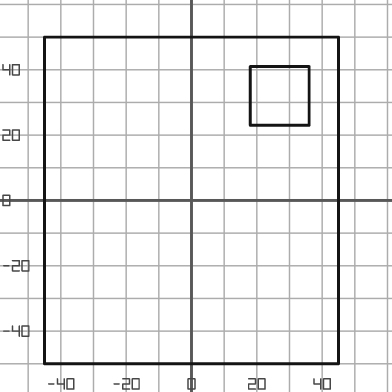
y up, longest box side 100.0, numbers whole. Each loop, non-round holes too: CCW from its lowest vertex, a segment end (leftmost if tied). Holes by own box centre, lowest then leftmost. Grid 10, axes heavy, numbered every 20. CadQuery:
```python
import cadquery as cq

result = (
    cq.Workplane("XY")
    .moveTo(-45.0, -50.0)
    .lineTo(45.0, -50.0)
    .lineTo(45.0, 50.0)
    .lineTo(-45.0, 50.0)
    .close()
    .moveTo(18.0, 23.0)
    .lineTo(36.0, 23.0)
    .lineTo(36.0, 41.0)
    .lineTo(18.0, 41.0)
    .close()
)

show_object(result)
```